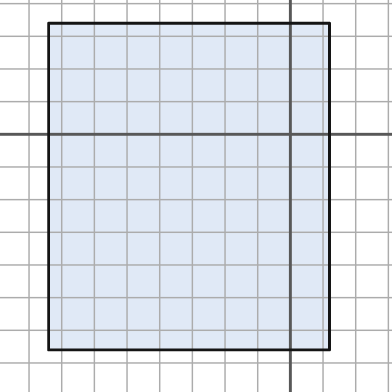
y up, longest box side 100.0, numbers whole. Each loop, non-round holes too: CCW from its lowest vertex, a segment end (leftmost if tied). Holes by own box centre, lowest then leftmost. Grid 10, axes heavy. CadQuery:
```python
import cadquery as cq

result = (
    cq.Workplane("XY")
    .moveTo(-74.0, -66.0)
    .lineTo(12.0, -66.0)
    .lineTo(12.0, 34.0)
    .lineTo(-74.0, 34.0)
    .close()
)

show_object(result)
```